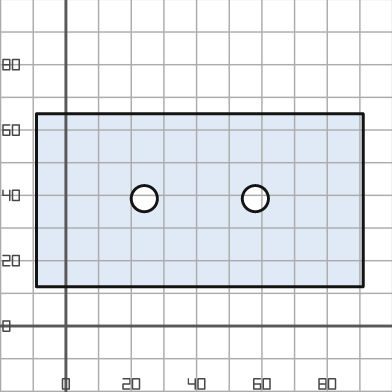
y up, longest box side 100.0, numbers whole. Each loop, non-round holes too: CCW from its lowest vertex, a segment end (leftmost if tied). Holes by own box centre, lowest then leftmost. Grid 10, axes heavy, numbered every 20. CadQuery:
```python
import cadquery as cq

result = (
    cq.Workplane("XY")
    .moveTo(-9.0, 12.0)
    .lineTo(91.0, 12.0)
    .lineTo(91.0, 65.0)
    .lineTo(-9.0, 65.0)
    .close()
    .moveTo(24.0, 39.0)
    .circle(4.0)
    .moveTo(58.0, 39.0)
    .circle(4.0)
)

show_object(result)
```